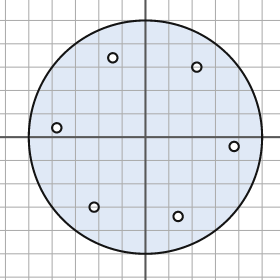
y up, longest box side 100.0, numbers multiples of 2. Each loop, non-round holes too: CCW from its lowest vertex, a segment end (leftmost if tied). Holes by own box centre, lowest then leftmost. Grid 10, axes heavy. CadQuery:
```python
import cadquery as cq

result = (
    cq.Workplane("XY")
    .moveTo(0.0, 0.0)
    .circle(50.0)
    .moveTo(14.0, -34.0)
    .circle(2.0)
    .moveTo(-22.0, -30.0)
    .circle(2.0)
    .moveTo(38.0, -4.0)
    .circle(2.0)
    .moveTo(-38.0, 4.0)
    .circle(2.0)
    .moveTo(22.0, 30.0)
    .circle(2.0)
    .moveTo(-14.0, 34.0)
    .circle(2.0)
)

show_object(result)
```